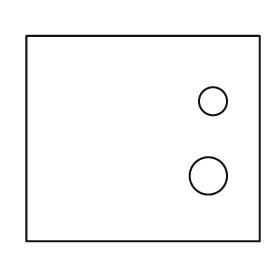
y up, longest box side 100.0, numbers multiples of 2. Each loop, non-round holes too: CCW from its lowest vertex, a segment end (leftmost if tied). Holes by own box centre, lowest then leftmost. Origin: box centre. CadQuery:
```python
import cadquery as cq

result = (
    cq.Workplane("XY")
    .moveTo(-50.0, -44.0)
    .lineTo(50.0, -44.0)
    .lineTo(50.0, 44.0)
    .lineTo(-50.0, 44.0)
    .close()
    .moveTo(28.0, -16.0)
    .circle(8.0)
    .moveTo(30.0, 16.0)
    .circle(6.0)
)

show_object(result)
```